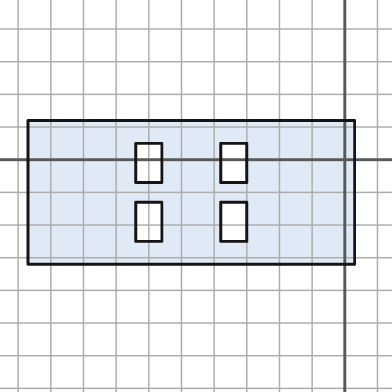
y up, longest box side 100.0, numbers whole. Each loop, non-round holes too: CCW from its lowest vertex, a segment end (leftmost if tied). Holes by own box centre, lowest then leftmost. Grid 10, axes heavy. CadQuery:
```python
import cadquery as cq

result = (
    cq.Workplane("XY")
    .moveTo(-97.0, -32.0)
    .lineTo(3.0, -32.0)
    .lineTo(3.0, 12.0)
    .lineTo(-97.0, 12.0)
    .close()
    .moveTo(-64.0, -25.0)
    .lineTo(-56.0, -25.0)
    .lineTo(-56.0, -13.0)
    .lineTo(-64.0, -13.0)
    .close()
    .moveTo(-38.0, -25.0)
    .lineTo(-30.0, -25.0)
    .lineTo(-30.0, -13.0)
    .lineTo(-38.0, -13.0)
    .close()
    .moveTo(-64.0, -7.0)
    .lineTo(-56.0, -7.0)
    .lineTo(-56.0, 5.0)
    .lineTo(-64.0, 5.0)
    .close()
    .moveTo(-38.0, -7.0)
    .lineTo(-30.0, -7.0)
    .lineTo(-30.0, 5.0)
    .lineTo(-38.0, 5.0)
    .close()
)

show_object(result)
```